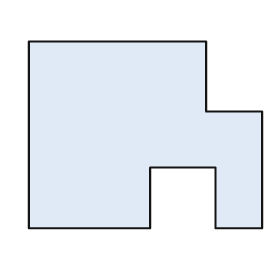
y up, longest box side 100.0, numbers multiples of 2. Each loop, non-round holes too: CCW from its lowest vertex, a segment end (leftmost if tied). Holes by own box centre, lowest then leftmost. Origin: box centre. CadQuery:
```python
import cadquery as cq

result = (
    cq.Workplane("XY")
    .moveTo(-50.0, -40.0)
    .lineTo(2.0, -40.0)
    .lineTo(2.0, -14.0)
    .lineTo(30.0, -14.0)
    .lineTo(30.0, -40.0)
    .lineTo(50.0, -40.0)
    .lineTo(50.0, 10.0)
    .lineTo(26.0, 10.0)
    .lineTo(26.0, 40.0)
    .lineTo(-50.0, 40.0)
    .close()
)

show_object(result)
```